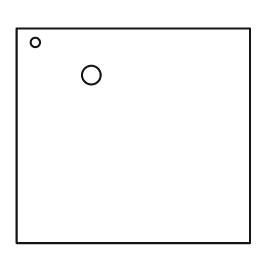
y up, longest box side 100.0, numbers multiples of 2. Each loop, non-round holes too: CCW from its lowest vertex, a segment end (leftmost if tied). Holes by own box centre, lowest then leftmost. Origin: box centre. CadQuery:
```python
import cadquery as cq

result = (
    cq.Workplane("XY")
    .moveTo(-50.0, -46.0)
    .lineTo(50.0, -46.0)
    .lineTo(50.0, 46.0)
    .lineTo(-50.0, 46.0)
    .close()
    .moveTo(-18.0, 26.0)
    .circle(4.0)
    .moveTo(-42.0, 40.0)
    .circle(2.0)
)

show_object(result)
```